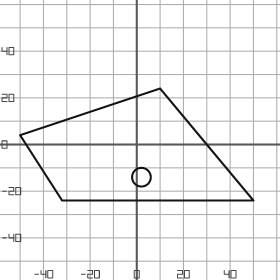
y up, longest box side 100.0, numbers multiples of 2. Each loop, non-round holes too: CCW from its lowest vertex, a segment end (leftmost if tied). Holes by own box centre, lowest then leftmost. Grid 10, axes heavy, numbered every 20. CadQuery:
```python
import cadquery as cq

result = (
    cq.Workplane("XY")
    .moveTo(-32.0, -24.0)
    .lineTo(50.0, -24.0)
    .lineTo(10.0, 24.0)
    .lineTo(-50.0, 4.0)
    .close()
    .moveTo(2.0, -14.0)
    .circle(4.0)
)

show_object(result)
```